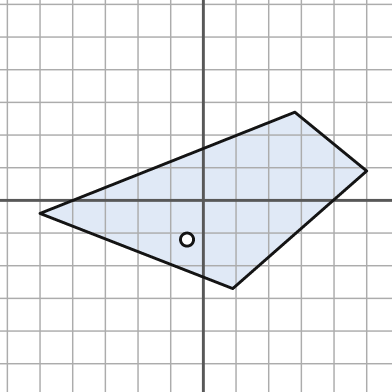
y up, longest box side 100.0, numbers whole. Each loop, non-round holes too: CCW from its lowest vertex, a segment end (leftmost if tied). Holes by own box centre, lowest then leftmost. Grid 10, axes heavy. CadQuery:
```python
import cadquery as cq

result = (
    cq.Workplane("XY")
    .moveTo(9.0, -27.0)
    .lineTo(50.0, 9.0)
    .lineTo(28.0, 27.0)
    .lineTo(-50.0, -4.0)
    .close()
    .moveTo(-5.0, -12.0)
    .circle(2.0)
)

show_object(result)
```